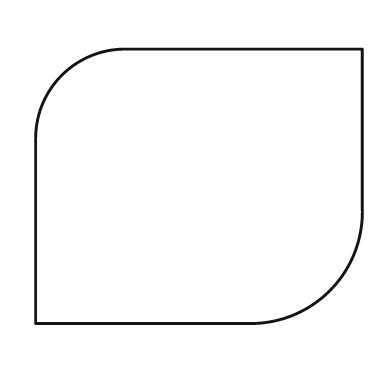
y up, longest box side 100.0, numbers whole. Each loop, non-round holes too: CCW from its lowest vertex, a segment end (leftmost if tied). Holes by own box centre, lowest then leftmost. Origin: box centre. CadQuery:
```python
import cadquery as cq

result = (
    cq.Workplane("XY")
    .moveTo(-50.0, -42.0)
    .lineTo(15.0, -42.0)
    .threePointArc((40.0, -32.0), (50.0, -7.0))
    .lineTo(50.0, 42.0)
    .lineTo(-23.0, 42.0)
    .threePointArc((-42.0, 34.0), (-50.0, 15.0))
    .close()
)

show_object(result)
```